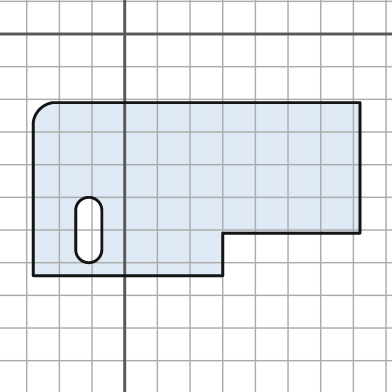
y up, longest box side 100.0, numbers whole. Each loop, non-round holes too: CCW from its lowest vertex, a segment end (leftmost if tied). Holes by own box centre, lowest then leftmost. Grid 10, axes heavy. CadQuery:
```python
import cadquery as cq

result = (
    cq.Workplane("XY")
    .moveTo(-28.0, -74.0)
    .lineTo(30.0, -74.0)
    .lineTo(30.0, -61.0)
    .lineTo(72.0, -61.0)
    .lineTo(72.0, -21.0)
    .lineTo(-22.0, -21.0)
    .threePointArc((-26.0, -23.0), (-28.0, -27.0))
    .close()
    .moveTo(-15.0, -66.0)
    .threePointArc((-11.0, -70.0), (-7.0, -66.0))
    .lineTo(-7.0, -54.0)
    .threePointArc((-11.0, -50.0), (-15.0, -54.0))
    .close()
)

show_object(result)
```